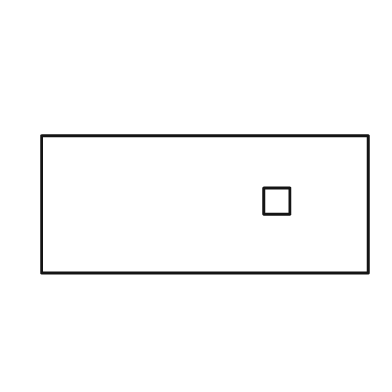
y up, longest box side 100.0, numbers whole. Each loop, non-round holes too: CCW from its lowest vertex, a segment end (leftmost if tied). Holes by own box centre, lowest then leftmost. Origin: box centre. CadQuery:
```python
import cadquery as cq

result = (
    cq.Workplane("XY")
    .moveTo(-50.0, -21.0)
    .lineTo(50.0, -21.0)
    .lineTo(50.0, 21.0)
    .lineTo(-50.0, 21.0)
    .close()
    .moveTo(18.0, -3.0)
    .lineTo(26.0, -3.0)
    .lineTo(26.0, 5.0)
    .lineTo(18.0, 5.0)
    .close()
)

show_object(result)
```